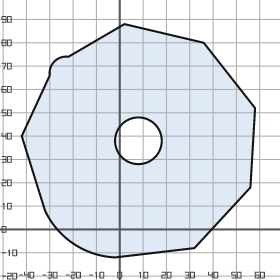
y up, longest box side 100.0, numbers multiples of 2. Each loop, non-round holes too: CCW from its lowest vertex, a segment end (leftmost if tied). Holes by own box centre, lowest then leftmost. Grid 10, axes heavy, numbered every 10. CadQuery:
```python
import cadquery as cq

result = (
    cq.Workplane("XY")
    .moveTo(-2.0, -12.0)
    .lineTo(32.0, -8.0)
    .lineTo(56.0, 18.0)
    .lineTo(58.0, 52.0)
    .lineTo(36.0, 80.0)
    .lineTo(2.0, 88.0)
    .lineTo(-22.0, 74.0)
    .threePointArc((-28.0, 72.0), (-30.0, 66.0))
    .lineTo(-42.0, 40.0)
    .lineTo(-32.0, 8.0)
    .threePointArc((-20.0, -6.0), (-2.0, -12.0))
    .close()
    .moveTo(8.0, 38.0)
    .circle(10.0)
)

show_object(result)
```